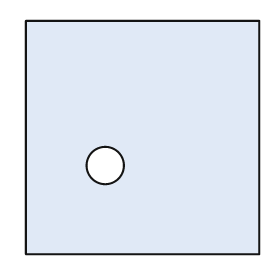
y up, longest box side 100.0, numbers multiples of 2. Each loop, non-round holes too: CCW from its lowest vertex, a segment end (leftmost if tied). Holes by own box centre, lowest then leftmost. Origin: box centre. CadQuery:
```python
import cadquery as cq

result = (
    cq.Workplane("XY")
    .moveTo(-50.0, -50.0)
    .lineTo(50.0, -50.0)
    .lineTo(50.0, 50.0)
    .lineTo(-50.0, 50.0)
    .close()
    .moveTo(-16.0, -12.0)
    .circle(8.0)
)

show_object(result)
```